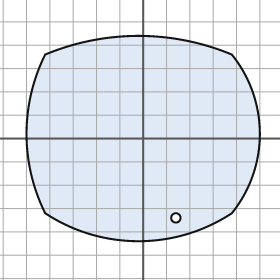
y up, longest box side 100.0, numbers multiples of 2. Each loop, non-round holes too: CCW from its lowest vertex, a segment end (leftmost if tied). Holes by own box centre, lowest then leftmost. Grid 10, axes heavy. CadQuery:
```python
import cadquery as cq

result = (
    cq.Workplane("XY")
    .moveTo(-42.0, -32.0)
    .threePointArc((-2.0, -44.0), (38.0, -32.0))
    .threePointArc((50.0, 2.0), (38.0, 36.0))
    .threePointArc((-2.0, 44.0), (-42.0, 36.0))
    .threePointArc((-50.0, 2.0), (-42.0, -32.0))
    .close()
    .moveTo(14.0, -34.0)
    .circle(2.0)
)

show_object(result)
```